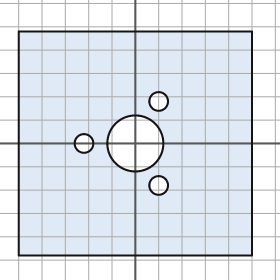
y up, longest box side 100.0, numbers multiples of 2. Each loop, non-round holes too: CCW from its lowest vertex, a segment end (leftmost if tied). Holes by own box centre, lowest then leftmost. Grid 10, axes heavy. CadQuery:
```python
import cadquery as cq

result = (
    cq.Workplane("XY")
    .moveTo(-50.0, -48.0)
    .lineTo(50.0, -48.0)
    .lineTo(50.0, 48.0)
    .lineTo(-50.0, 48.0)
    .close()
    .moveTo(10.0, -18.0)
    .circle(4.0)
    .moveTo(-22.0, 0.0)
    .circle(4.0)
    .moveTo(0.0, 0.0)
    .circle(12.0)
    .moveTo(10.0, 18.0)
    .circle(4.0)
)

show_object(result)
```